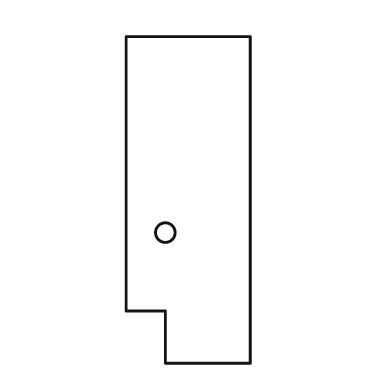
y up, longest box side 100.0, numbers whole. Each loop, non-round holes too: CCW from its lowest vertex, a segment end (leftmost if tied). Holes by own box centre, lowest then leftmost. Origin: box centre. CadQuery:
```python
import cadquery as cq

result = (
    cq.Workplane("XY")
    .moveTo(-7.0, -50.0)
    .lineTo(19.0, -50.0)
    .lineTo(19.0, 50.0)
    .lineTo(-19.0, 50.0)
    .lineTo(-19.0, -34.0)
    .lineTo(-7.0, -34.0)
    .close()
    .moveTo(-7.0, -10.0)
    .circle(3.0)
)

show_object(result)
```